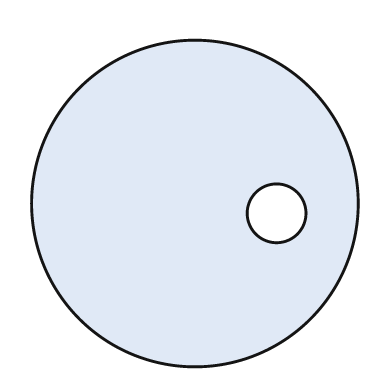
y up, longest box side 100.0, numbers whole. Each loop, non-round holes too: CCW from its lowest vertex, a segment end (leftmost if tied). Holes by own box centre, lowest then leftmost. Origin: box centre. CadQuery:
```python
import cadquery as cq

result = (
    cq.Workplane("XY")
    .moveTo(0.0, 0.0)
    .circle(50.0)
    .moveTo(25.0, -3.0)
    .circle(9.0)
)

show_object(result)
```